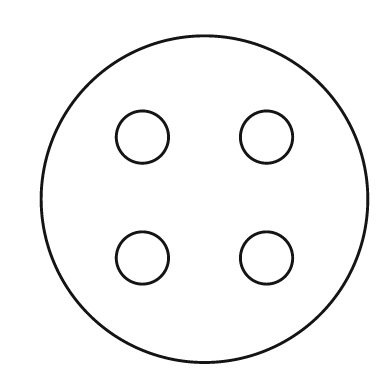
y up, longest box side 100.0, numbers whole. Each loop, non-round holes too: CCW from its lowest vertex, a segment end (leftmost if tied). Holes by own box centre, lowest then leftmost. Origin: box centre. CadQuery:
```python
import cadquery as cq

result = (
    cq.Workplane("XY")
    .moveTo(0.0, 0.0)
    .circle(50.0)
    .moveTo(-19.0, -18.0)
    .circle(8.0)
    .moveTo(19.0, -18.0)
    .circle(8.0)
    .moveTo(-19.0, 19.0)
    .circle(8.0)
    .moveTo(19.0, 19.0)
    .circle(8.0)
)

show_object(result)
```